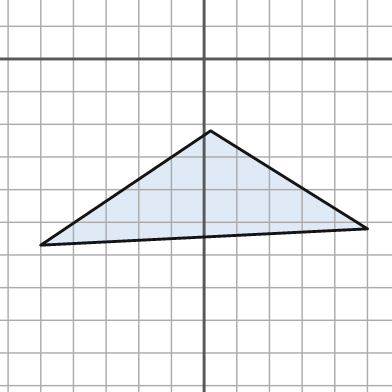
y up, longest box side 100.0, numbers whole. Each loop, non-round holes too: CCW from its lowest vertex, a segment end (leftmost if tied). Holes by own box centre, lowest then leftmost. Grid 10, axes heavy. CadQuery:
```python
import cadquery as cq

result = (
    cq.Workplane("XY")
    .moveTo(-50.0, -57.0)
    .lineTo(50.0, -52.0)
    .lineTo(2.0, -22.0)
    .close()
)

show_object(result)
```